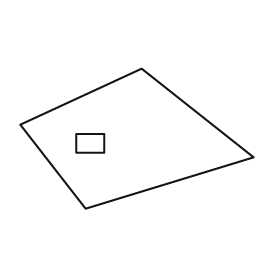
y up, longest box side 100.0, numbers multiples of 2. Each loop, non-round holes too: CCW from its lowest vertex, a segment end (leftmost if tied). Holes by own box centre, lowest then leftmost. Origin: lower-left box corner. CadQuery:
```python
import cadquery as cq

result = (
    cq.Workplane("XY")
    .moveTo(28.0, 0.0)
    .lineTo(100.0, 22.0)
    .lineTo(52.0, 60.0)
    .lineTo(0.0, 36.0)
    .close()
    .moveTo(24.0, 24.0)
    .lineTo(36.0, 24.0)
    .lineTo(36.0, 32.0)
    .lineTo(24.0, 32.0)
    .close()
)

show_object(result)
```